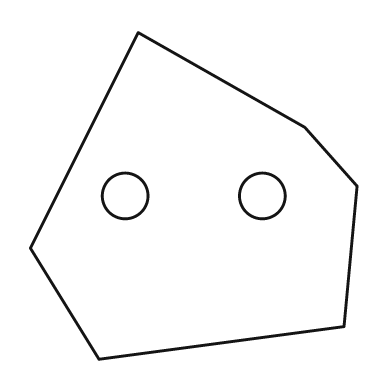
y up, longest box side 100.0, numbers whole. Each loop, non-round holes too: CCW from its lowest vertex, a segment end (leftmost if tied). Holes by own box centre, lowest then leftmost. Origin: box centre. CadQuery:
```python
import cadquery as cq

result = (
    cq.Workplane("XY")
    .moveTo(-29.0, -50.0)
    .lineTo(46.0, -40.0)
    .lineTo(50.0, 3.0)
    .lineTo(34.0, 21.0)
    .lineTo(-17.0, 50.0)
    .lineTo(-50.0, -16.0)
    .close()
    .moveTo(-21.0, 0.0)
    .circle(7.0)
    .moveTo(21.0, 0.0)
    .circle(7.0)
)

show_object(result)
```